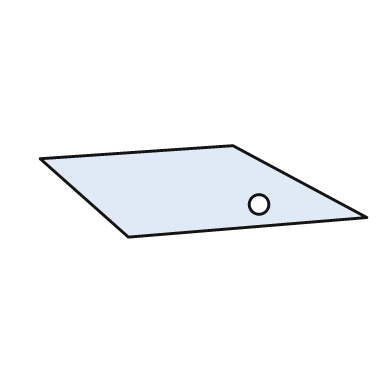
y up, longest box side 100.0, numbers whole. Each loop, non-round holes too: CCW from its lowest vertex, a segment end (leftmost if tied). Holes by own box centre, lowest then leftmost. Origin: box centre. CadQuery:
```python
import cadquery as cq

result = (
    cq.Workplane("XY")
    .moveTo(-23.0, -14.0)
    .lineTo(50.0, -8.0)
    .lineTo(9.0, 14.0)
    .lineTo(-50.0, 10.0)
    .close()
    .moveTo(17.0, -4.0)
    .circle(3.0)
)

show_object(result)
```